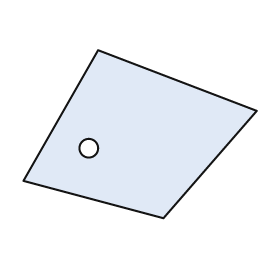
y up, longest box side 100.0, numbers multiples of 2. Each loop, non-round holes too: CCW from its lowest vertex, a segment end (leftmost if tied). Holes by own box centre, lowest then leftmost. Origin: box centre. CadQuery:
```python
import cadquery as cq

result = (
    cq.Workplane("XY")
    .moveTo(10.0, -36.0)
    .lineTo(50.0, 10.0)
    .lineTo(-18.0, 36.0)
    .lineTo(-50.0, -20.0)
    .close()
    .moveTo(-22.0, -6.0)
    .circle(4.0)
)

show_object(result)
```